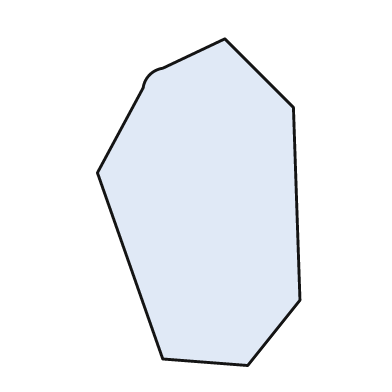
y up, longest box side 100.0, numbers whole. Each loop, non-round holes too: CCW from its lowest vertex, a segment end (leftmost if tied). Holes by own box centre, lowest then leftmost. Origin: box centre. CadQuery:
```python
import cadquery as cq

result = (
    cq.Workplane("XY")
    .moveTo(15.0, -50.0)
    .lineTo(31.0, -30.0)
    .lineTo(29.0, 29.0)
    .lineTo(8.0, 50.0)
    .lineTo(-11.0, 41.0)
    .threePointArc((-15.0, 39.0), (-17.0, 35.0))
    .lineTo(-31.0, 9.0)
    .lineTo(-11.0, -48.0)
    .close()
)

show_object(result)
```